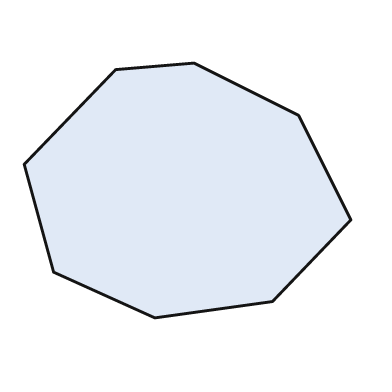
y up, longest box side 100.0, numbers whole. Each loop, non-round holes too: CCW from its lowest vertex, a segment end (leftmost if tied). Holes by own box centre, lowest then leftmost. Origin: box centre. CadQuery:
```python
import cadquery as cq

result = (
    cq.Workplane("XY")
    .moveTo(-10.0, -39.0)
    .lineTo(26.0, -34.0)
    .lineTo(50.0, -9.0)
    .lineTo(34.0, 23.0)
    .lineTo(2.0, 39.0)
    .lineTo(-22.0, 37.0)
    .lineTo(-50.0, 8.0)
    .lineTo(-41.0, -25.0)
    .close()
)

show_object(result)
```